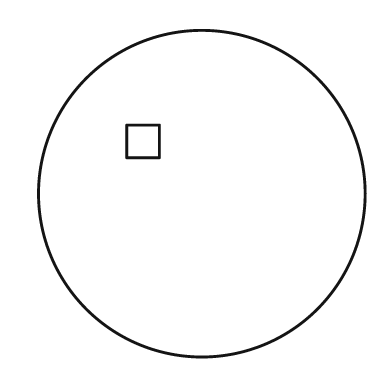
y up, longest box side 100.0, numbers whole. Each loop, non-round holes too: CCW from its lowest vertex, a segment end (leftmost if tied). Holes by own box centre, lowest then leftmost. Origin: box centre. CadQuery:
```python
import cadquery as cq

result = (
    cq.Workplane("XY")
    .moveTo(0.0, 0.0)
    .circle(50.0)
    .moveTo(-23.0, 11.0)
    .lineTo(-13.0, 11.0)
    .lineTo(-13.0, 21.0)
    .lineTo(-23.0, 21.0)
    .close()
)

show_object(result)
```